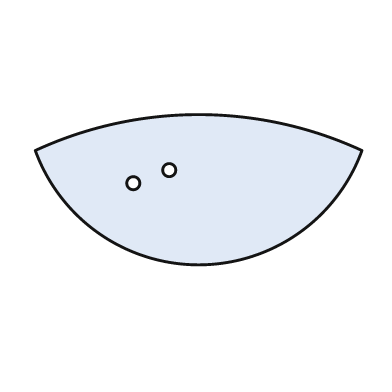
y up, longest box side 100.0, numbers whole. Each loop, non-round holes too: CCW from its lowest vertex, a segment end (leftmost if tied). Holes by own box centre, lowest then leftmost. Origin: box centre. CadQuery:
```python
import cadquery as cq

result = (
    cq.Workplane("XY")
    .moveTo(-50.0, 12.0)
    .threePointArc((0.0, -23.0), (50.0, 12.0))
    .threePointArc((0.0, 23.0), (-50.0, 12.0))
    .close()
    .moveTo(-20.0, 2.0)
    .circle(2.0)
    .moveTo(-9.0, 6.0)
    .circle(2.0)
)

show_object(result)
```